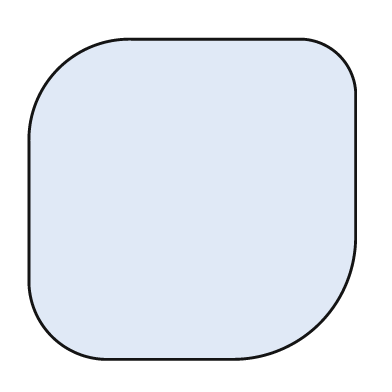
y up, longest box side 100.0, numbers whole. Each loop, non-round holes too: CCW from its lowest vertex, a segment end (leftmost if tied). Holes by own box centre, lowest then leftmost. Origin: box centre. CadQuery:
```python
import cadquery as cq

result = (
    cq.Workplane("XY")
    .moveTo(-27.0, -49.0)
    .lineTo(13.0, -49.0)
    .threePointArc((39.0, -38.0), (50.0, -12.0))
    .lineTo(50.0, 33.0)
    .threePointArc((45.0, 44.0), (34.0, 49.0))
    .lineTo(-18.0, 49.0)
    .threePointArc((-41.0, 40.0), (-50.0, 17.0))
    .lineTo(-50.0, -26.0)
    .threePointArc((-43.0, -42.0), (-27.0, -49.0))
    .close()
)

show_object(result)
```